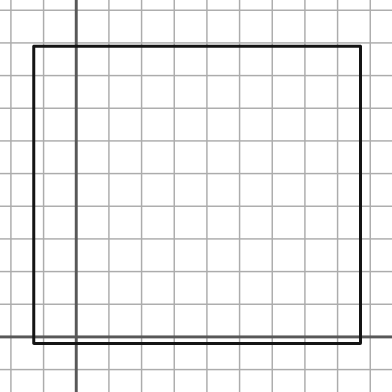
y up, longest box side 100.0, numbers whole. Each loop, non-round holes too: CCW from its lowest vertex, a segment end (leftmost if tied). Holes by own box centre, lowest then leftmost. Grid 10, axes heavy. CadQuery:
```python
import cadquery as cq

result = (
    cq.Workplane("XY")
    .moveTo(-13.0, -2.0)
    .lineTo(87.0, -2.0)
    .lineTo(87.0, 89.0)
    .lineTo(-13.0, 89.0)
    .close()
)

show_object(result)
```